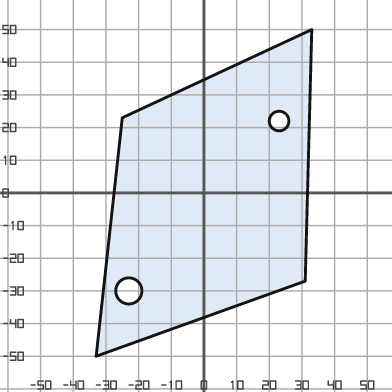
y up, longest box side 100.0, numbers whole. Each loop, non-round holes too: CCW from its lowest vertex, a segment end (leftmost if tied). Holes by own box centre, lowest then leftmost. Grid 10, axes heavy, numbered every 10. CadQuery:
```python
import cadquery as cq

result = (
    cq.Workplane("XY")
    .moveTo(-33.0, -50.0)
    .lineTo(31.0, -27.0)
    .lineTo(33.0, 50.0)
    .lineTo(-25.0, 23.0)
    .close()
    .moveTo(-23.0, -30.0)
    .circle(4.0)
    .moveTo(23.0, 22.0)
    .circle(3.0)
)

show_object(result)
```